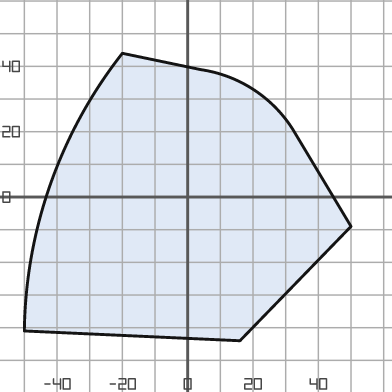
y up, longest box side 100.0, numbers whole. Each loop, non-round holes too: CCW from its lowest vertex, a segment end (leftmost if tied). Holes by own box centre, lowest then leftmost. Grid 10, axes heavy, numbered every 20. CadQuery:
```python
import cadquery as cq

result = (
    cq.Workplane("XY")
    .moveTo(16.0, -44.0)
    .lineTo(50.0, -9.0)
    .lineTo(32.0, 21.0)
    .threePointArc((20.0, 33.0), (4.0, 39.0))
    .lineTo(-20.0, 44.0)
    .threePointArc((-42.0, 4.0), (-50.0, -41.0))
    .close()
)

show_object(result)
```